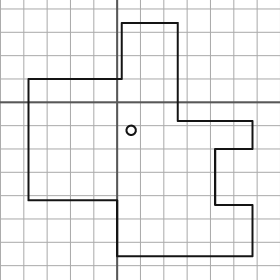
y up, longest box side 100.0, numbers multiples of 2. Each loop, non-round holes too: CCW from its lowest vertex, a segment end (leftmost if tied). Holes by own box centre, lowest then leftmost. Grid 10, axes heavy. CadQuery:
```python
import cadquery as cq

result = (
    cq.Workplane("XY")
    .moveTo(0.0, -66.0)
    .lineTo(58.0, -66.0)
    .lineTo(58.0, -44.0)
    .lineTo(42.0, -44.0)
    .lineTo(42.0, -20.0)
    .lineTo(58.0, -20.0)
    .lineTo(58.0, -8.0)
    .lineTo(26.0, -8.0)
    .lineTo(26.0, 34.0)
    .lineTo(2.0, 34.0)
    .lineTo(2.0, 10.0)
    .lineTo(-38.0, 10.0)
    .lineTo(-38.0, -42.0)
    .lineTo(0.0, -42.0)
    .close()
    .moveTo(6.0, -12.0)
    .circle(2.0)
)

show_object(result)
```